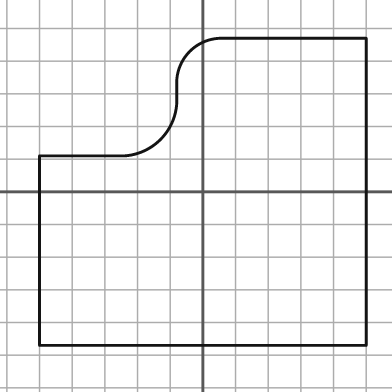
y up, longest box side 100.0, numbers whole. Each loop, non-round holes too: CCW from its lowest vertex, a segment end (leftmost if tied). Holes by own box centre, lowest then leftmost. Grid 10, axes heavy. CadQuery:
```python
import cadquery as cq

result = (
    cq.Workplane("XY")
    .moveTo(-50.0, -47.0)
    .lineTo(50.0, -47.0)
    .lineTo(50.0, 47.0)
    .lineTo(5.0, 47.0)
    .threePointArc((-4.0, 43.0), (-8.0, 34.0))
    .lineTo(-8.0, 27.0)
    .threePointArc((-13.0, 16.0), (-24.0, 11.0))
    .lineTo(-50.0, 11.0)
    .close()
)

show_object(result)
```